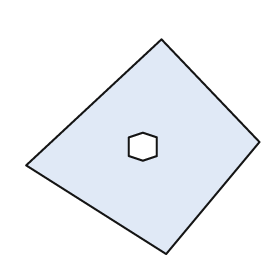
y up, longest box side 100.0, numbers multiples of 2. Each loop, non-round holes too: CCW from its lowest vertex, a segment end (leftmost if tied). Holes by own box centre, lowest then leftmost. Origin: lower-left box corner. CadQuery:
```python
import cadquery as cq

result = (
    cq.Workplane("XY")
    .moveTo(60.0, 0.0)
    .lineTo(100.0, 48.0)
    .lineTo(58.0, 92.0)
    .lineTo(0.0, 38.0)
    .close()
    .moveTo(50.0, 40.0)
    .lineTo(56.0, 42.0)
    .lineTo(56.0, 50.0)
    .lineTo(50.0, 52.0)
    .lineTo(44.0, 50.0)
    .lineTo(44.0, 42.0)
    .close()
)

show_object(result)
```